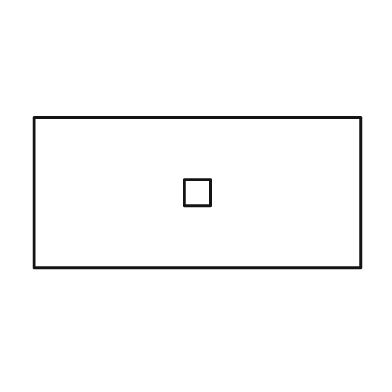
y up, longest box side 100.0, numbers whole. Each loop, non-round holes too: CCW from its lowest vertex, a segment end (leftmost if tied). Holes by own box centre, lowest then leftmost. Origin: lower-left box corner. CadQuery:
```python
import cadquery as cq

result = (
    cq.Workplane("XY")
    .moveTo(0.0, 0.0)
    .lineTo(100.0, 0.0)
    .lineTo(100.0, 46.0)
    .lineTo(0.0, 46.0)
    .close()
    .moveTo(46.0, 19.0)
    .lineTo(54.0, 19.0)
    .lineTo(54.0, 27.0)
    .lineTo(46.0, 27.0)
    .close()
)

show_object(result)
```